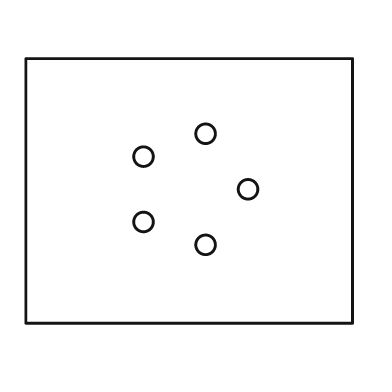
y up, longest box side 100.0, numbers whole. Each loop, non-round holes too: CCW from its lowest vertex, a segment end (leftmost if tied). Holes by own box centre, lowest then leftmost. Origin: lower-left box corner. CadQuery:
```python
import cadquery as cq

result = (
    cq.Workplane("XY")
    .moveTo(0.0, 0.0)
    .lineTo(100.0, 0.0)
    .lineTo(100.0, 81.0)
    .lineTo(0.0, 81.0)
    .close()
    .moveTo(55.0, 24.0)
    .circle(3.0)
    .moveTo(36.0, 31.0)
    .circle(3.0)
    .moveTo(68.0, 41.0)
    .circle(3.0)
    .moveTo(36.0, 51.0)
    .circle(3.0)
    .moveTo(55.0, 58.0)
    .circle(3.0)
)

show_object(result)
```